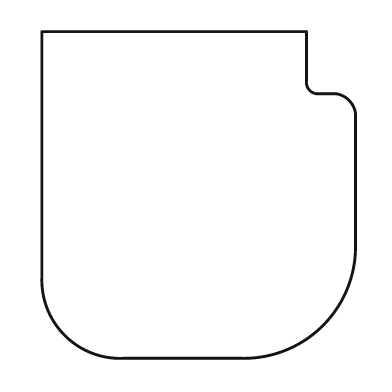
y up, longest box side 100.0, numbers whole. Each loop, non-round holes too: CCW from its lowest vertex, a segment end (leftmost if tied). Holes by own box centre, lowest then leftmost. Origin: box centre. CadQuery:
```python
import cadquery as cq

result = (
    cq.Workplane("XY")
    .moveTo(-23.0, -50.0)
    .lineTo(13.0, -50.0)
    .threePointArc((38.0, -40.0), (48.0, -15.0))
    .lineTo(48.0, 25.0)
    .threePointArc((46.0, 29.0), (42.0, 31.0))
    .lineTo(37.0, 31.0)
    .threePointArc((34.0, 32.0), (33.0, 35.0))
    .lineTo(33.0, 50.0)
    .lineTo(-48.0, 50.0)
    .lineTo(-48.0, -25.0)
    .threePointArc((-41.0, -43.0), (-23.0, -50.0))
    .close()
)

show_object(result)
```